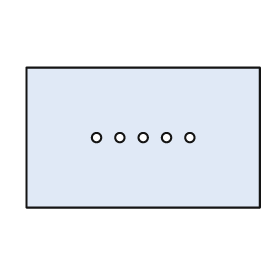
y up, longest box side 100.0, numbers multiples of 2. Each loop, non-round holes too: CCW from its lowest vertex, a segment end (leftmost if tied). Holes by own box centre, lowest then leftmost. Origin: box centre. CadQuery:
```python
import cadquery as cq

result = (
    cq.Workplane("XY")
    .moveTo(-50.0, -30.0)
    .lineTo(50.0, -30.0)
    .lineTo(50.0, 30.0)
    .lineTo(-50.0, 30.0)
    .close()
    .moveTo(-20.0, 0.0)
    .circle(2.0)
    .moveTo(-10.0, 0.0)
    .circle(2.0)
    .moveTo(0.0, 0.0)
    .circle(2.0)
    .moveTo(10.0, 0.0)
    .circle(2.0)
    .moveTo(20.0, 0.0)
    .circle(2.0)
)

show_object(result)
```